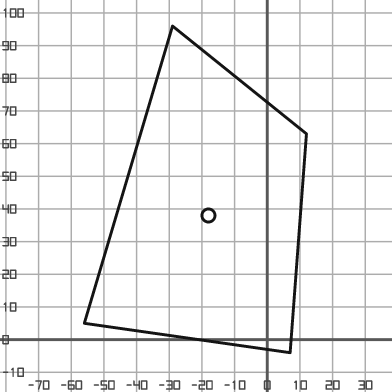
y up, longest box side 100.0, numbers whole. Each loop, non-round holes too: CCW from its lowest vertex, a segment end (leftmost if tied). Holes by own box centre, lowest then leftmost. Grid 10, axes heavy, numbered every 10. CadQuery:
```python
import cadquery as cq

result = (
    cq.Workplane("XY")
    .moveTo(7.0, -4.0)
    .lineTo(12.0, 63.0)
    .lineTo(-29.0, 96.0)
    .lineTo(-56.0, 5.0)
    .close()
    .moveTo(-18.0, 38.0)
    .circle(2.0)
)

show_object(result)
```